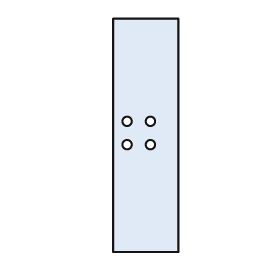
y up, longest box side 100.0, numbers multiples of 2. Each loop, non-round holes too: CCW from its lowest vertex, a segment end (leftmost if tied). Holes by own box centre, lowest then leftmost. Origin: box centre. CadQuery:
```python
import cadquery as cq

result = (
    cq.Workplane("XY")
    .moveTo(-14.0, -50.0)
    .lineTo(14.0, -50.0)
    .lineTo(14.0, 50.0)
    .lineTo(-14.0, 50.0)
    .close()
    .moveTo(-8.0, -4.0)
    .circle(2.0)
    .moveTo(2.0, -4.0)
    .circle(2.0)
    .moveTo(-8.0, 6.0)
    .circle(2.0)
    .moveTo(2.0, 6.0)
    .circle(2.0)
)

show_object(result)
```